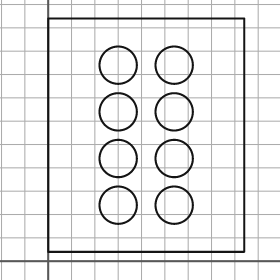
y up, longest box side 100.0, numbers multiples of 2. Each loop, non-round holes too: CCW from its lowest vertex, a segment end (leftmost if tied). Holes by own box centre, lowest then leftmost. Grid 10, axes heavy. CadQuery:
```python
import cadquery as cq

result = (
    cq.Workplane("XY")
    .moveTo(0.0, 4.0)
    .lineTo(84.0, 4.0)
    .lineTo(84.0, 104.0)
    .lineTo(0.0, 104.0)
    .close()
    .moveTo(30.0, 24.0)
    .circle(8.0)
    .moveTo(54.0, 24.0)
    .circle(8.0)
    .moveTo(30.0, 44.0)
    .circle(8.0)
    .moveTo(54.0, 44.0)
    .circle(8.0)
    .moveTo(30.0, 64.0)
    .circle(8.0)
    .moveTo(54.0, 64.0)
    .circle(8.0)
    .moveTo(30.0, 84.0)
    .circle(8.0)
    .moveTo(54.0, 84.0)
    .circle(8.0)
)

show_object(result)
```